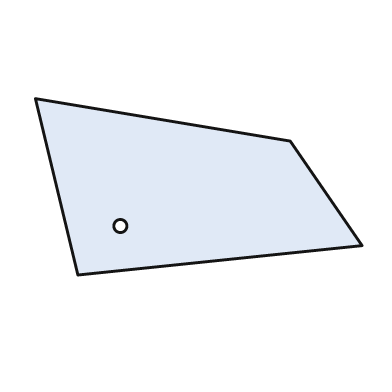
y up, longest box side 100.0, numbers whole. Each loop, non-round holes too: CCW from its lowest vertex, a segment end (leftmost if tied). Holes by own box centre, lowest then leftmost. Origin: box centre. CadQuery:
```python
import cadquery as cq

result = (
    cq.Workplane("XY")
    .moveTo(-37.0, -27.0)
    .lineTo(50.0, -18.0)
    .lineTo(28.0, 14.0)
    .lineTo(-50.0, 27.0)
    .close()
    .moveTo(-24.0, -12.0)
    .circle(2.0)
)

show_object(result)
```